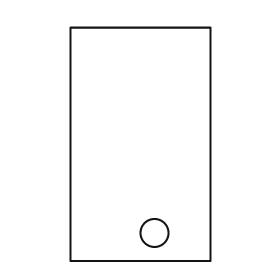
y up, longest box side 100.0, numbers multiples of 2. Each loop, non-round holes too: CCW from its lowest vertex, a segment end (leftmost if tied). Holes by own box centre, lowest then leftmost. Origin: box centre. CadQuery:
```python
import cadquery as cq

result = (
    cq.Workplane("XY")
    .moveTo(-30.0, -50.0)
    .lineTo(30.0, -50.0)
    .lineTo(30.0, 50.0)
    .lineTo(-30.0, 50.0)
    .close()
    .moveTo(6.0, -38.0)
    .circle(6.0)
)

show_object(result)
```